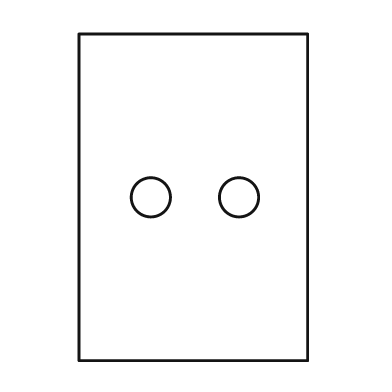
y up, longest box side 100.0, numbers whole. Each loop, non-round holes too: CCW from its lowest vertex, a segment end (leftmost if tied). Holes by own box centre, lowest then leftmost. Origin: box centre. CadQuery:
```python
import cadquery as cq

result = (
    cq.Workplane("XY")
    .moveTo(-35.0, -50.0)
    .lineTo(35.0, -50.0)
    .lineTo(35.0, 50.0)
    .lineTo(-35.0, 50.0)
    .close()
    .moveTo(-13.0, 0.0)
    .circle(6.0)
    .moveTo(14.0, 0.0)
    .circle(6.0)
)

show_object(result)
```